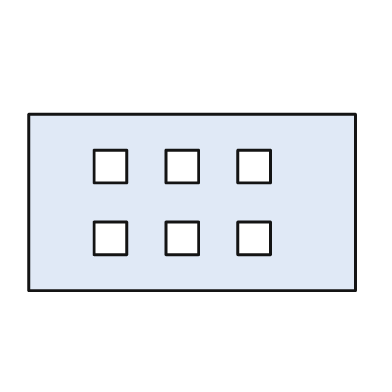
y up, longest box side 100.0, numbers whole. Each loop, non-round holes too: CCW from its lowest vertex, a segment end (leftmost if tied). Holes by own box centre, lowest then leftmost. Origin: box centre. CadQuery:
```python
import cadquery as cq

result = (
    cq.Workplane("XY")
    .moveTo(-50.0, -27.0)
    .lineTo(50.0, -27.0)
    .lineTo(50.0, 27.0)
    .lineTo(-50.0, 27.0)
    .close()
    .moveTo(-30.0, -16.0)
    .lineTo(-20.0, -16.0)
    .lineTo(-20.0, -6.0)
    .lineTo(-30.0, -6.0)
    .close()
    .moveTo(-8.0, -16.0)
    .lineTo(2.0, -16.0)
    .lineTo(2.0, -6.0)
    .lineTo(-8.0, -6.0)
    .close()
    .moveTo(14.0, -16.0)
    .lineTo(24.0, -16.0)
    .lineTo(24.0, -6.0)
    .lineTo(14.0, -6.0)
    .close()
    .moveTo(-30.0, 6.0)
    .lineTo(-20.0, 6.0)
    .lineTo(-20.0, 16.0)
    .lineTo(-30.0, 16.0)
    .close()
    .moveTo(-8.0, 6.0)
    .lineTo(2.0, 6.0)
    .lineTo(2.0, 16.0)
    .lineTo(-8.0, 16.0)
    .close()
    .moveTo(14.0, 6.0)
    .lineTo(24.0, 6.0)
    .lineTo(24.0, 16.0)
    .lineTo(14.0, 16.0)
    .close()
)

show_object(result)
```